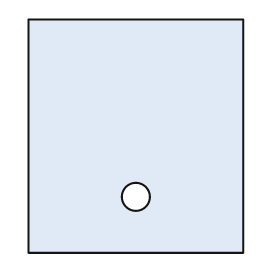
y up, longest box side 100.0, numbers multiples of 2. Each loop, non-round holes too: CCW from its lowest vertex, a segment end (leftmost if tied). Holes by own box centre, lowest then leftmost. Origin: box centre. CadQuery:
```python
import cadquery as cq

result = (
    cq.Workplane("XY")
    .moveTo(-46.0, -50.0)
    .lineTo(46.0, -50.0)
    .lineTo(46.0, 50.0)
    .lineTo(-46.0, 50.0)
    .close()
    .moveTo(0.0, -26.0)
    .circle(6.0)
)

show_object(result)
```